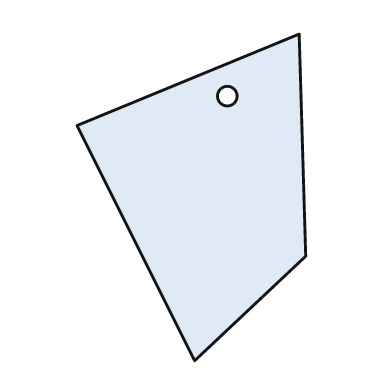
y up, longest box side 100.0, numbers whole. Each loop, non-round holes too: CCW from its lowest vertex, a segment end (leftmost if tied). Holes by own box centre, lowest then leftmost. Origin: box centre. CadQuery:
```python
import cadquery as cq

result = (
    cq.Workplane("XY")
    .moveTo(1.0, -50.0)
    .lineTo(35.0, -18.0)
    .lineTo(33.0, 50.0)
    .lineTo(-35.0, 22.0)
    .close()
    .moveTo(11.0, 31.0)
    .circle(3.0)
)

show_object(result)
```